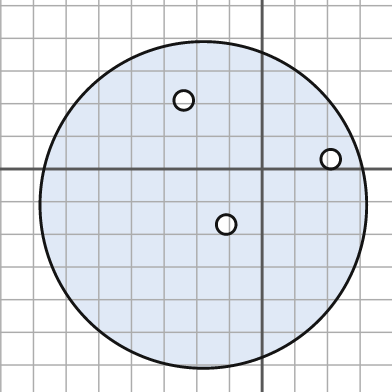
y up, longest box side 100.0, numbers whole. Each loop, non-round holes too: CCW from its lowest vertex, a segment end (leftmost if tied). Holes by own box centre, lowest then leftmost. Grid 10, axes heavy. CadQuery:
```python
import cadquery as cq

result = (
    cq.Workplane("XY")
    .moveTo(-18.0, -11.0)
    .circle(50.0)
    .moveTo(-11.0, -17.0)
    .circle(3.0)
    .moveTo(21.0, 3.0)
    .circle(3.0)
    .moveTo(-24.0, 21.0)
    .circle(3.0)
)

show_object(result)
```